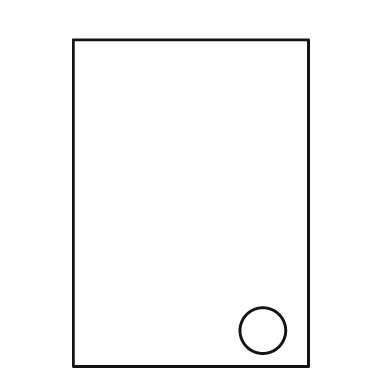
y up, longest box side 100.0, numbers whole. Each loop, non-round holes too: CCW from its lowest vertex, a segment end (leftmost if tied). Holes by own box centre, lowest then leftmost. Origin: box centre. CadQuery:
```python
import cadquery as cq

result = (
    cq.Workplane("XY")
    .moveTo(-36.0, -50.0)
    .lineTo(36.0, -50.0)
    .lineTo(36.0, 50.0)
    .lineTo(-36.0, 50.0)
    .close()
    .moveTo(22.0, -39.0)
    .circle(7.0)
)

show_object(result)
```